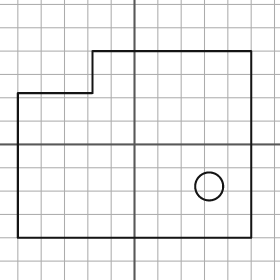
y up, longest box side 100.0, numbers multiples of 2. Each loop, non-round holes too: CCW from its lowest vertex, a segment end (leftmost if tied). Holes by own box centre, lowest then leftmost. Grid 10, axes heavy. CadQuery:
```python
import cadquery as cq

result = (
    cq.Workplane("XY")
    .moveTo(-50.0, -40.0)
    .lineTo(50.0, -40.0)
    .lineTo(50.0, 40.0)
    .lineTo(-18.0, 40.0)
    .lineTo(-18.0, 22.0)
    .lineTo(-50.0, 22.0)
    .close()
    .moveTo(32.0, -18.0)
    .circle(6.0)
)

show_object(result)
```